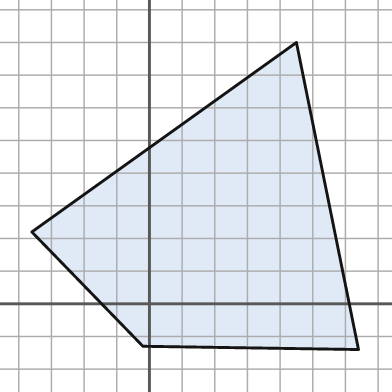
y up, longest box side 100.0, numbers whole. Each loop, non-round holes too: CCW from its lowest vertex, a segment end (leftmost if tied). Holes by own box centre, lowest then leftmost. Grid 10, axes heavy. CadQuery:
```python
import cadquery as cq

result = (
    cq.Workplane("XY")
    .moveTo(64.0, -14.0)
    .lineTo(45.0, 80.0)
    .lineTo(-36.0, 22.0)
    .lineTo(-2.0, -13.0)
    .close()
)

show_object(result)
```